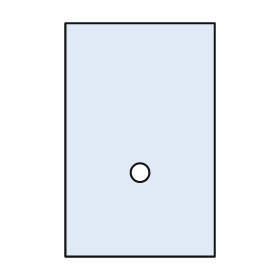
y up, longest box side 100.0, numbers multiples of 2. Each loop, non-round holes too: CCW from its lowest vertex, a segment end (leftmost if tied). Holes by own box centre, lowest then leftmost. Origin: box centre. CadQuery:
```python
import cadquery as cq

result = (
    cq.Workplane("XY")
    .moveTo(-32.0, -50.0)
    .lineTo(32.0, -50.0)
    .lineTo(32.0, 50.0)
    .lineTo(-32.0, 50.0)
    .close()
    .moveTo(0.0, -14.0)
    .circle(4.0)
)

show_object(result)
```